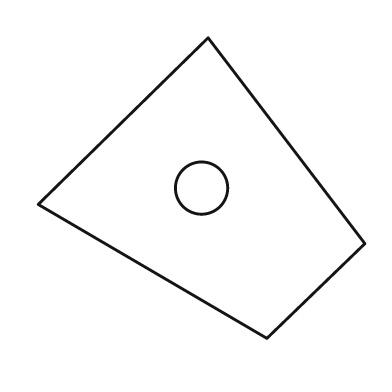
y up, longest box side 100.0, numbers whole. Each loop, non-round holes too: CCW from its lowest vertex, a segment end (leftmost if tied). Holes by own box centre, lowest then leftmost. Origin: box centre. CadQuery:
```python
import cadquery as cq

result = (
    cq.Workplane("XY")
    .moveTo(20.0, -46.0)
    .lineTo(50.0, -17.0)
    .lineTo(2.0, 46.0)
    .lineTo(-50.0, -5.0)
    .close()
    .moveTo(0.0, 0.0)
    .circle(8.0)
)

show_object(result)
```